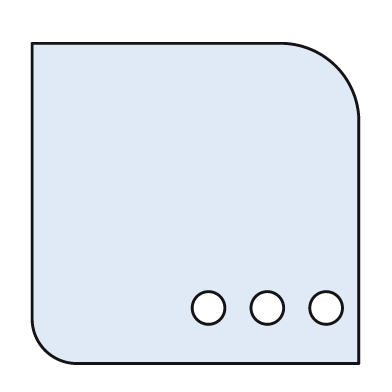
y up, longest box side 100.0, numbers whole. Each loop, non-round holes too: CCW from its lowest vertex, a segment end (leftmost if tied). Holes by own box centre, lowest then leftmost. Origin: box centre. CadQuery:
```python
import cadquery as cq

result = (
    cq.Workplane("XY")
    .moveTo(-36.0, -49.0)
    .lineTo(50.0, -49.0)
    .lineTo(50.0, 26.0)
    .threePointArc((43.0, 42.0), (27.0, 49.0))
    .lineTo(-50.0, 49.0)
    .lineTo(-50.0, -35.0)
    .threePointArc((-46.0, -45.0), (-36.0, -49.0))
    .close()
    .moveTo(4.0, -32.0)
    .circle(5.0)
    .moveTo(22.0, -32.0)
    .circle(5.0)
    .moveTo(40.0, -32.0)
    .circle(5.0)
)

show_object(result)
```